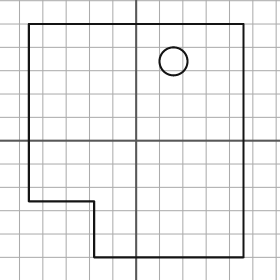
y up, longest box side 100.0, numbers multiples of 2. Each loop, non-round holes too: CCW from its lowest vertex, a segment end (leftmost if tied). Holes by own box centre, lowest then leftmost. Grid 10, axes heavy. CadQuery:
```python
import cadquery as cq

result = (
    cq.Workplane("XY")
    .moveTo(-18.0, -50.0)
    .lineTo(46.0, -50.0)
    .lineTo(46.0, 50.0)
    .lineTo(-46.0, 50.0)
    .lineTo(-46.0, -26.0)
    .lineTo(-18.0, -26.0)
    .close()
    .moveTo(16.0, 34.0)
    .circle(6.0)
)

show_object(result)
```